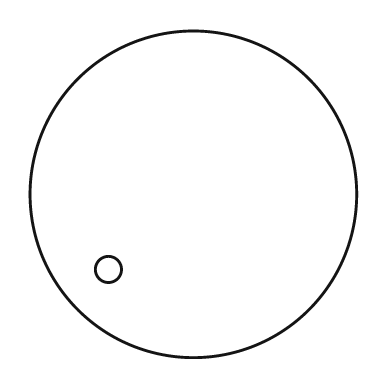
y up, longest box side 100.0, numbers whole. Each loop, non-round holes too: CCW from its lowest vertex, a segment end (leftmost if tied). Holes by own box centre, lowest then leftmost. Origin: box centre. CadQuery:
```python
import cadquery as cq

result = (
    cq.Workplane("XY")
    .moveTo(0.0, 0.0)
    .circle(50.0)
    .moveTo(-26.0, -23.0)
    .circle(4.0)
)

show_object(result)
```